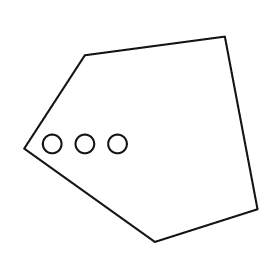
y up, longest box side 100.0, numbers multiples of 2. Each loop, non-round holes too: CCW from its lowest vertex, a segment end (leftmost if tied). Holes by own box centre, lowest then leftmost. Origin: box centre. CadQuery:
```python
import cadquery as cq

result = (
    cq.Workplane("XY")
    .moveTo(6.0, -44.0)
    .lineTo(50.0, -30.0)
    .lineTo(36.0, 44.0)
    .lineTo(-24.0, 36.0)
    .lineTo(-50.0, -4.0)
    .close()
    .moveTo(-38.0, -2.0)
    .circle(4.0)
    .moveTo(-24.0, -2.0)
    .circle(4.0)
    .moveTo(-10.0, -2.0)
    .circle(4.0)
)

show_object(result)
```